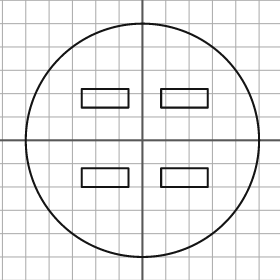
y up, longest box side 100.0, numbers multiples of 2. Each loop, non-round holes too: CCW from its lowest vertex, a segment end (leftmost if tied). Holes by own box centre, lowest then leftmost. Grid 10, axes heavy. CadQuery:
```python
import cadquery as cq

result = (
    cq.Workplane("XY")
    .moveTo(0.0, 0.0)
    .circle(50.0)
    .moveTo(-26.0, -20.0)
    .lineTo(-6.0, -20.0)
    .lineTo(-6.0, -12.0)
    .lineTo(-26.0, -12.0)
    .close()
    .moveTo(8.0, -20.0)
    .lineTo(28.0, -20.0)
    .lineTo(28.0, -12.0)
    .lineTo(8.0, -12.0)
    .close()
    .moveTo(-26.0, 14.0)
    .lineTo(-6.0, 14.0)
    .lineTo(-6.0, 22.0)
    .lineTo(-26.0, 22.0)
    .close()
    .moveTo(8.0, 14.0)
    .lineTo(28.0, 14.0)
    .lineTo(28.0, 22.0)
    .lineTo(8.0, 22.0)
    .close()
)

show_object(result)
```